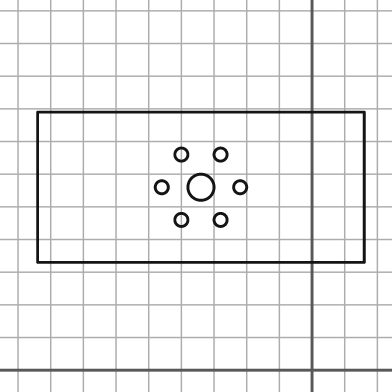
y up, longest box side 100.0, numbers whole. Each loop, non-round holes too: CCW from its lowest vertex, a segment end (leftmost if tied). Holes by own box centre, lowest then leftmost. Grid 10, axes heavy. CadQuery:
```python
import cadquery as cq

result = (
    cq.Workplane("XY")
    .moveTo(-84.0, 33.0)
    .lineTo(16.0, 33.0)
    .lineTo(16.0, 79.0)
    .lineTo(-84.0, 79.0)
    .close()
    .moveTo(-40.0, 46.0)
    .circle(2.0)
    .moveTo(-28.0, 46.0)
    .circle(2.0)
    .moveTo(-46.0, 56.0)
    .circle(2.0)
    .moveTo(-34.0, 56.0)
    .circle(4.0)
    .moveTo(-22.0, 56.0)
    .circle(2.0)
    .moveTo(-40.0, 66.0)
    .circle(2.0)
    .moveTo(-28.0, 66.0)
    .circle(2.0)
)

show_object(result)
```